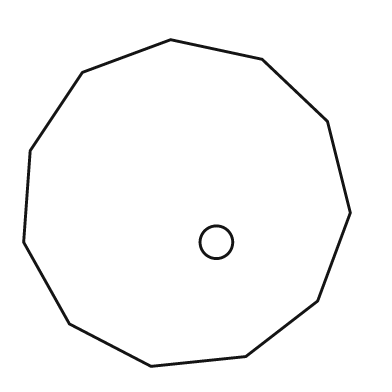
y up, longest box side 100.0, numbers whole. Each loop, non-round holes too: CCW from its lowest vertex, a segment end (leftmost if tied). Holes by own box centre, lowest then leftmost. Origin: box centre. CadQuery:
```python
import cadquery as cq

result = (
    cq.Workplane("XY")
    .moveTo(-11.0, -50.0)
    .lineTo(18.0, -47.0)
    .lineTo(40.0, -30.0)
    .lineTo(50.0, -3.0)
    .lineTo(43.0, 25.0)
    .lineTo(23.0, 44.0)
    .lineTo(-5.0, 50.0)
    .lineTo(-32.0, 40.0)
    .lineTo(-48.0, 16.0)
    .lineTo(-50.0, -12.0)
    .lineTo(-36.0, -37.0)
    .close()
    .moveTo(9.0, -12.0)
    .circle(5.0)
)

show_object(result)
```